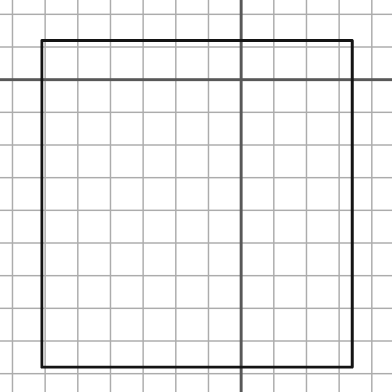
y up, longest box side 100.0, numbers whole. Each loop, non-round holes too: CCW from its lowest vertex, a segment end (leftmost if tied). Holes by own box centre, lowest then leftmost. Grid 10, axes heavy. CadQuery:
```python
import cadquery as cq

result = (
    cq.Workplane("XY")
    .moveTo(-61.0, -88.0)
    .lineTo(34.0, -88.0)
    .lineTo(34.0, 12.0)
    .lineTo(-61.0, 12.0)
    .close()
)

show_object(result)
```